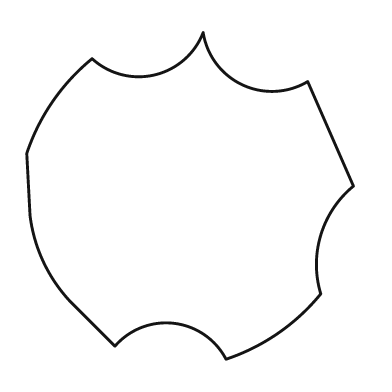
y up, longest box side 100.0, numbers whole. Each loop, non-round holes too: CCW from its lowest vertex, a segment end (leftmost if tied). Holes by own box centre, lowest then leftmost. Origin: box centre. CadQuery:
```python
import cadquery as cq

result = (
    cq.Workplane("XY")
    .moveTo(11.0, -50.0)
    .threePointArc((27.0, -42.0), (40.0, -30.0))
    .threePointArc((40.0, -12.0), (50.0, 3.0))
    .lineTo(36.0, 35.0)
    .threePointArc((16.0, 34.0), (4.0, 50.0))
    .threePointArc((-11.0, 37.0), (-30.0, 42.0))
    .threePointArc((-42.0, 29.0), (-50.0, 13.0))
    .lineTo(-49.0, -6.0)
    .threePointArc((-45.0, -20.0), (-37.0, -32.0))
    .lineTo(-23.0, -46.0)
    .threePointArc((-5.0, -39.0), (11.0, -50.0))
    .close()
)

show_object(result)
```